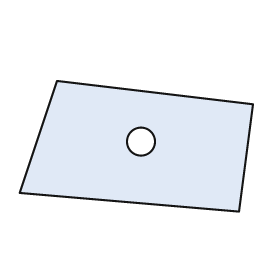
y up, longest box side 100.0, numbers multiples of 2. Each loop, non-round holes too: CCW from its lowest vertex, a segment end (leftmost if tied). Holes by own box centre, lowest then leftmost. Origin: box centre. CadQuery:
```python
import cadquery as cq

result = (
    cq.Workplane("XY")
    .moveTo(44.0, -28.0)
    .lineTo(50.0, 18.0)
    .lineTo(-34.0, 28.0)
    .lineTo(-50.0, -20.0)
    .close()
    .moveTo(2.0, 2.0)
    .circle(6.0)
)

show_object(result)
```